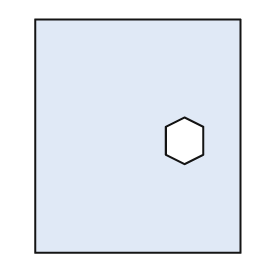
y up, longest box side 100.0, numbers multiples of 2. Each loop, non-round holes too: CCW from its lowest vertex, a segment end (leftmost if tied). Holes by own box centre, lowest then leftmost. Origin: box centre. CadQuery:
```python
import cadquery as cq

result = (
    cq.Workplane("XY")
    .moveTo(-44.0, -50.0)
    .lineTo(44.0, -50.0)
    .lineTo(44.0, 50.0)
    .lineTo(-44.0, 50.0)
    .close()
    .moveTo(20.0, -12.0)
    .lineTo(28.0, -8.0)
    .lineTo(28.0, 4.0)
    .lineTo(20.0, 8.0)
    .lineTo(12.0, 4.0)
    .lineTo(12.0, -8.0)
    .close()
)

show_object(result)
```